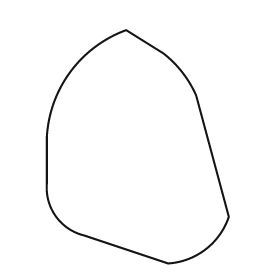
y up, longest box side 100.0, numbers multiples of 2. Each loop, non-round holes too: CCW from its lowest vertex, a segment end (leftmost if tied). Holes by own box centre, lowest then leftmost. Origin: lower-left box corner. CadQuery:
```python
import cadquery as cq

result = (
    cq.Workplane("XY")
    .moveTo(52.0, 0.0)
    .threePointArc((68.0, 6.0), (78.0, 20.0))
    .lineTo(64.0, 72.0)
    .threePointArc((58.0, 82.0), (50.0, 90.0))
    .lineTo(34.0, 100.0)
    .threePointArc((10.0, 82.0), (0.0, 54.0))
    .lineTo(0.0, 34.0)
    .threePointArc((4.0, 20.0), (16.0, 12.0))
    .close()
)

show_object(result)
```